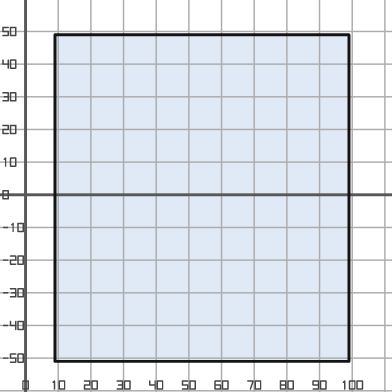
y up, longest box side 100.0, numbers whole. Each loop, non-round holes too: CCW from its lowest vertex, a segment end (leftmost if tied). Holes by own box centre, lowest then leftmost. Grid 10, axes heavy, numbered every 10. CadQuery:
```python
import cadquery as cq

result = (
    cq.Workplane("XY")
    .moveTo(9.0, -51.0)
    .lineTo(99.0, -51.0)
    .lineTo(99.0, 49.0)
    .lineTo(9.0, 49.0)
    .close()
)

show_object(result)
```